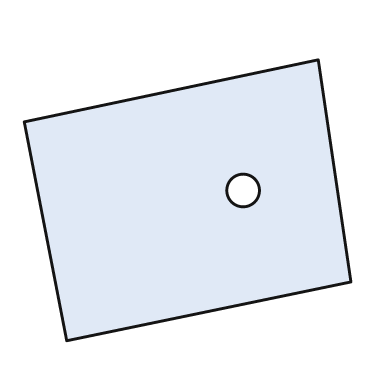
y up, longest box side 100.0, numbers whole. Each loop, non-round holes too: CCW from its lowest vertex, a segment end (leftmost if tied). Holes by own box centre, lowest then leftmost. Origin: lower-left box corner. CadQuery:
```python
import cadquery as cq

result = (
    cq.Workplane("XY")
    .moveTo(13.0, 0.0)
    .lineTo(100.0, 18.0)
    .lineTo(90.0, 86.0)
    .lineTo(0.0, 67.0)
    .close()
    .moveTo(67.0, 46.0)
    .circle(5.0)
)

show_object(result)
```